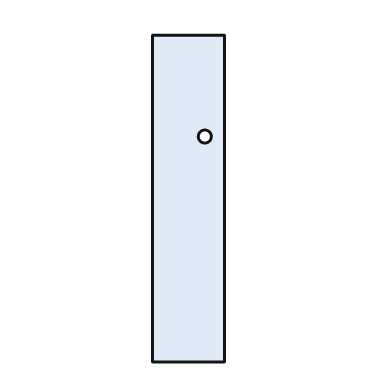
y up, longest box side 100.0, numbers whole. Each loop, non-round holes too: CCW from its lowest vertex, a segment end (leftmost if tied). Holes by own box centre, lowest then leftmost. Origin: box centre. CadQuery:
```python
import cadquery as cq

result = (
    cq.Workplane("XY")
    .moveTo(-11.0, -50.0)
    .lineTo(11.0, -50.0)
    .lineTo(11.0, 50.0)
    .lineTo(-11.0, 50.0)
    .close()
    .moveTo(5.0, 19.0)
    .circle(2.0)
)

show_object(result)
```